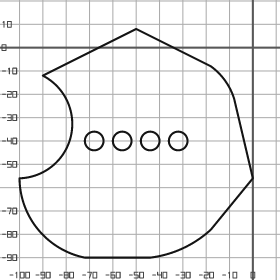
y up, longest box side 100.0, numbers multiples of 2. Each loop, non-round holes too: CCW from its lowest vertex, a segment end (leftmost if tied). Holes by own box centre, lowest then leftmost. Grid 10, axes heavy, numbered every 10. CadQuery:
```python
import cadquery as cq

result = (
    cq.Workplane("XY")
    .moveTo(-72.0, -90.0)
    .lineTo(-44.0, -90.0)
    .threePointArc((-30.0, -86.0), (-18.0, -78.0))
    .lineTo(0.0, -56.0)
    .lineTo(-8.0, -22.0)
    .threePointArc((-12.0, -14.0), (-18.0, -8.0))
    .lineTo(-50.0, 8.0)
    .lineTo(-90.0, -12.0)
    .threePointArc((-78.0, -38.0), (-100.0, -56.0))
    .threePointArc((-92.0, -78.0), (-72.0, -90.0))
    .close()
    .moveTo(-68.0, -40.0)
    .circle(4.0)
    .moveTo(-56.0, -40.0)
    .circle(4.0)
    .moveTo(-44.0, -40.0)
    .circle(4.0)
    .moveTo(-32.0, -40.0)
    .circle(4.0)
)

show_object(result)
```